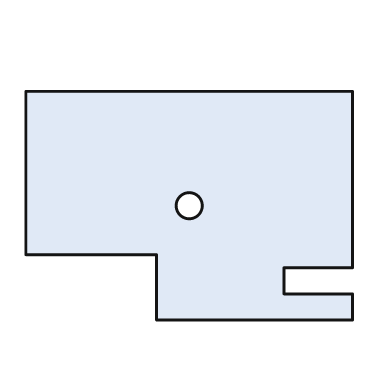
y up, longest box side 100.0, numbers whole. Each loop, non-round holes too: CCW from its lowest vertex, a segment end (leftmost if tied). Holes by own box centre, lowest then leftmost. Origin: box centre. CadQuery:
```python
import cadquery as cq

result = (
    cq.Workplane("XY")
    .moveTo(-10.0, -35.0)
    .lineTo(50.0, -35.0)
    .lineTo(50.0, -27.0)
    .lineTo(29.0, -27.0)
    .lineTo(29.0, -19.0)
    .lineTo(50.0, -19.0)
    .lineTo(50.0, 35.0)
    .lineTo(-50.0, 35.0)
    .lineTo(-50.0, -15.0)
    .lineTo(-10.0, -15.0)
    .close()
    .moveTo(0.0, 0.0)
    .circle(4.0)
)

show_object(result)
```